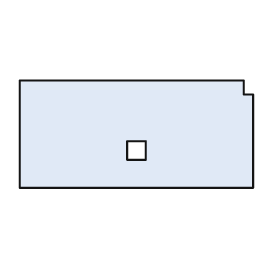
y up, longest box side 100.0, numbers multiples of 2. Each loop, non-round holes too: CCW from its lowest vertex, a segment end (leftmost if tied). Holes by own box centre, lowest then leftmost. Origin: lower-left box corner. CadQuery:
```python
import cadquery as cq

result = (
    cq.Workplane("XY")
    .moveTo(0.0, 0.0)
    .lineTo(100.0, 0.0)
    .lineTo(100.0, 40.0)
    .lineTo(96.0, 40.0)
    .lineTo(96.0, 46.0)
    .lineTo(0.0, 46.0)
    .close()
    .moveTo(46.0, 12.0)
    .lineTo(54.0, 12.0)
    .lineTo(54.0, 20.0)
    .lineTo(46.0, 20.0)
    .close()
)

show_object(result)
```